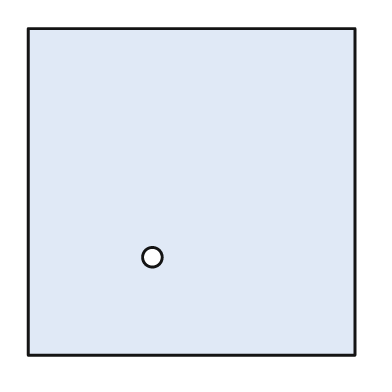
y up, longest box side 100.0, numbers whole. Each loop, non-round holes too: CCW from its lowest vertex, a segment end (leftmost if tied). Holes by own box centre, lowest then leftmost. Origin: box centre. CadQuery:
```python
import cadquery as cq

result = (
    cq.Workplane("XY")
    .moveTo(-50.0, -50.0)
    .lineTo(50.0, -50.0)
    .lineTo(50.0, 50.0)
    .lineTo(-50.0, 50.0)
    .close()
    .moveTo(-12.0, -20.0)
    .circle(3.0)
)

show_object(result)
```